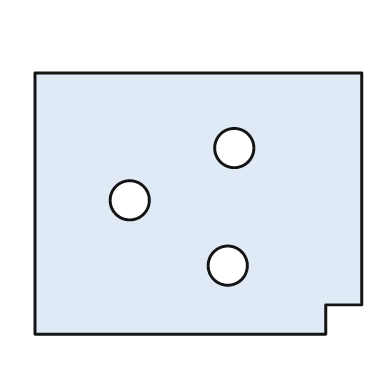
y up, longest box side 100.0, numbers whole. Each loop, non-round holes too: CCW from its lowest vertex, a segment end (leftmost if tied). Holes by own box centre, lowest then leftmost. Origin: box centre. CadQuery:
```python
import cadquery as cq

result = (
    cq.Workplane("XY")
    .moveTo(-50.0, -40.0)
    .lineTo(39.0, -40.0)
    .lineTo(39.0, -31.0)
    .lineTo(50.0, -31.0)
    .lineTo(50.0, 40.0)
    .lineTo(-50.0, 40.0)
    .close()
    .moveTo(9.0, -19.0)
    .circle(6.0)
    .moveTo(-21.0, 1.0)
    .circle(6.0)
    .moveTo(11.0, 17.0)
    .circle(6.0)
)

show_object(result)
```